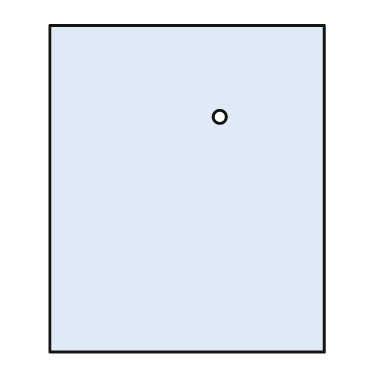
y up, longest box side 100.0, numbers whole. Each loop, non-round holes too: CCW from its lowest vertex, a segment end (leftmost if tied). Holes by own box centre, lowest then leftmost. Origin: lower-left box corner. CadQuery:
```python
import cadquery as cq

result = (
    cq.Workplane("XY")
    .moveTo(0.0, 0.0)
    .lineTo(84.0, 0.0)
    .lineTo(84.0, 100.0)
    .lineTo(0.0, 100.0)
    .close()
    .moveTo(52.0, 72.0)
    .circle(2.0)
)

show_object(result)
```